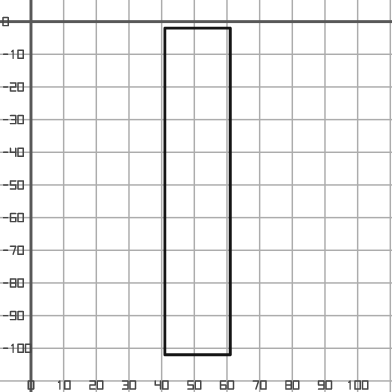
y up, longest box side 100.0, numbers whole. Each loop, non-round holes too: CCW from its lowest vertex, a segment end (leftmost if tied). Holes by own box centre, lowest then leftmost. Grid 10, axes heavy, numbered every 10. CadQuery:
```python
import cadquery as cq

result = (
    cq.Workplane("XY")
    .moveTo(41.0, -102.0)
    .lineTo(61.0, -102.0)
    .lineTo(61.0, -2.0)
    .lineTo(41.0, -2.0)
    .close()
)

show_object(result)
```